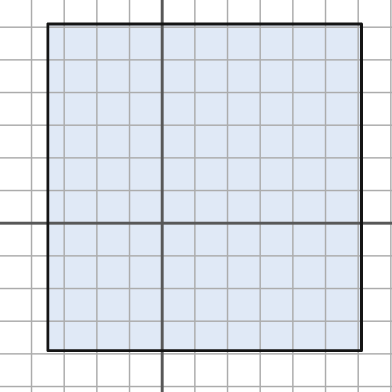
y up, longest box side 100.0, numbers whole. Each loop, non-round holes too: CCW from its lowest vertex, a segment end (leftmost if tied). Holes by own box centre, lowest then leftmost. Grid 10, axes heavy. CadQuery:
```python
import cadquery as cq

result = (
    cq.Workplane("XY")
    .moveTo(-35.0, -39.0)
    .lineTo(61.0, -39.0)
    .lineTo(61.0, 61.0)
    .lineTo(-35.0, 61.0)
    .close()
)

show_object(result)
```